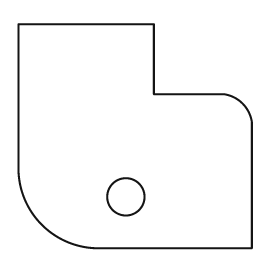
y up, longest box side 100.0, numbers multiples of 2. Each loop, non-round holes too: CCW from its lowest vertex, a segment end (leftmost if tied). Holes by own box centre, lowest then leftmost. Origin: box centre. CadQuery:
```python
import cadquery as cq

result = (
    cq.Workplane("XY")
    .moveTo(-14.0, -48.0)
    .lineTo(50.0, -48.0)
    .lineTo(50.0, 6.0)
    .threePointArc((46.0, 14.0), (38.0, 18.0))
    .lineTo(8.0, 18.0)
    .lineTo(8.0, 48.0)
    .lineTo(-50.0, 48.0)
    .lineTo(-50.0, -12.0)
    .threePointArc((-40.0, -38.0), (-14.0, -48.0))
    .close()
    .moveTo(-4.0, -26.0)
    .circle(8.0)
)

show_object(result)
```